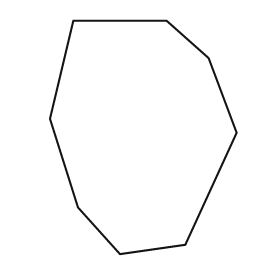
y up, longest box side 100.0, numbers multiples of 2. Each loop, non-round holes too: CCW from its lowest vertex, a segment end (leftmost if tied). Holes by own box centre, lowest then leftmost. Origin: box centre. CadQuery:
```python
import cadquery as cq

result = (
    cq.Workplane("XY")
    .moveTo(-10.0, -50.0)
    .lineTo(18.0, -46.0)
    .lineTo(40.0, 2.0)
    .lineTo(28.0, 34.0)
    .lineTo(10.0, 50.0)
    .lineTo(-30.0, 50.0)
    .lineTo(-40.0, 8.0)
    .lineTo(-28.0, -30.0)
    .close()
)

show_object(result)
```